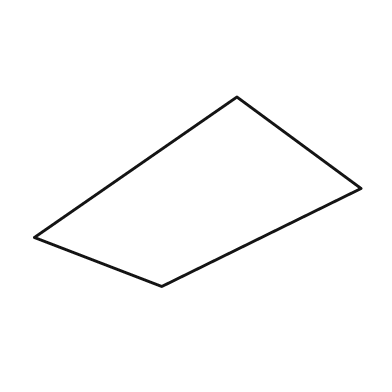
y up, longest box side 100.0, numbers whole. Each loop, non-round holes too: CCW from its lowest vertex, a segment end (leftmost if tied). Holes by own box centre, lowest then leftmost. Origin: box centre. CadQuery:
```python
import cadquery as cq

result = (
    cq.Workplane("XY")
    .moveTo(-11.0, -29.0)
    .lineTo(50.0, 1.0)
    .lineTo(12.0, 29.0)
    .lineTo(-50.0, -14.0)
    .close()
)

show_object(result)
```